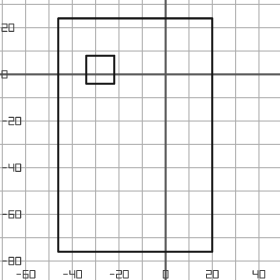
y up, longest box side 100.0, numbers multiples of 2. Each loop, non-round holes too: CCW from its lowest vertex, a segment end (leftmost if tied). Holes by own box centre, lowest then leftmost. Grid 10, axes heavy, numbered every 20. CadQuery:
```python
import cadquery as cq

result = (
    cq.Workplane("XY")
    .moveTo(-46.0, -76.0)
    .lineTo(20.0, -76.0)
    .lineTo(20.0, 24.0)
    .lineTo(-46.0, 24.0)
    .close()
    .moveTo(-34.0, -4.0)
    .lineTo(-22.0, -4.0)
    .lineTo(-22.0, 8.0)
    .lineTo(-34.0, 8.0)
    .close()
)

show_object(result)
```